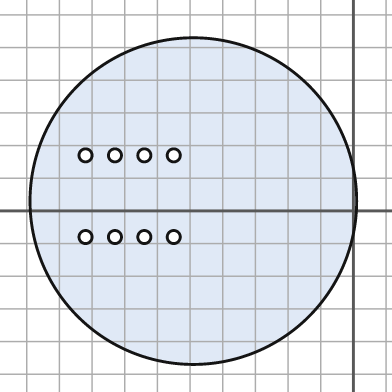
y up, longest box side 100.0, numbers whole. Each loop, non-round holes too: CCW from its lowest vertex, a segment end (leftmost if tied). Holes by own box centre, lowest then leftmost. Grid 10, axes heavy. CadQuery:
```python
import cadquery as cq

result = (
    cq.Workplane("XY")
    .moveTo(-49.0, 3.0)
    .circle(50.0)
    .moveTo(-82.0, -8.0)
    .circle(2.0)
    .moveTo(-73.0, -8.0)
    .circle(2.0)
    .moveTo(-64.0, -8.0)
    .circle(2.0)
    .moveTo(-55.0, -8.0)
    .circle(2.0)
    .moveTo(-82.0, 17.0)
    .circle(2.0)
    .moveTo(-73.0, 17.0)
    .circle(2.0)
    .moveTo(-64.0, 17.0)
    .circle(2.0)
    .moveTo(-55.0, 17.0)
    .circle(2.0)
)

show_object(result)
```